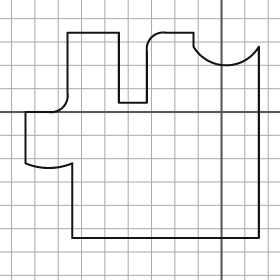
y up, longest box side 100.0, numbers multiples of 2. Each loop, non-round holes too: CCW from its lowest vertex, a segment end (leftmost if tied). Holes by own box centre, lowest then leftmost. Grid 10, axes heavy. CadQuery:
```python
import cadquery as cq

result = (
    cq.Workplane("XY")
    .moveTo(-64.0, -54.0)
    .lineTo(16.0, -54.0)
    .lineTo(16.0, 28.0)
    .threePointArc((2.0, 20.0), (-12.0, 28.0))
    .lineTo(-12.0, 34.0)
    .lineTo(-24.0, 34.0)
    .threePointArc((-30.0, 32.0), (-32.0, 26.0))
    .lineTo(-32.0, 4.0)
    .lineTo(-44.0, 4.0)
    .lineTo(-44.0, 34.0)
    .lineTo(-66.0, 34.0)
    .lineTo(-66.0, 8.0)
    .threePointArc((-68.0, 2.0), (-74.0, 0.0))
    .lineTo(-84.0, 0.0)
    .lineTo(-84.0, -22.0)
    .threePointArc((-74.0, -24.0), (-64.0, -22.0))
    .close()
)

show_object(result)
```